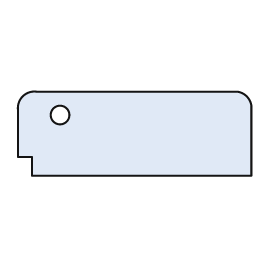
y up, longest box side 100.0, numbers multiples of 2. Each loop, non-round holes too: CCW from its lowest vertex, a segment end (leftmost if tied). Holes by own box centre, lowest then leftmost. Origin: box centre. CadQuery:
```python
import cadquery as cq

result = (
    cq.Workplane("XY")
    .moveTo(-44.0, -18.0)
    .lineTo(50.0, -18.0)
    .lineTo(50.0, 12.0)
    .threePointArc((48.0, 16.0), (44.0, 18.0))
    .lineTo(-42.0, 18.0)
    .threePointArc((-48.0, 16.0), (-50.0, 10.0))
    .lineTo(-50.0, -10.0)
    .lineTo(-44.0, -10.0)
    .close()
    .moveTo(-32.0, 8.0)
    .circle(4.0)
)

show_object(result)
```